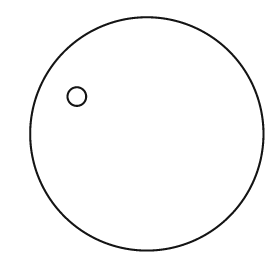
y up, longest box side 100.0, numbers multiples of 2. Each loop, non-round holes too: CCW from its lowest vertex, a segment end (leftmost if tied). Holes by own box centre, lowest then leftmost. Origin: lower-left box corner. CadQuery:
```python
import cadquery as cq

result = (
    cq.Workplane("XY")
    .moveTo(50.0, 50.0)
    .circle(50.0)
    .moveTo(20.0, 66.0)
    .circle(4.0)
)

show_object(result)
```